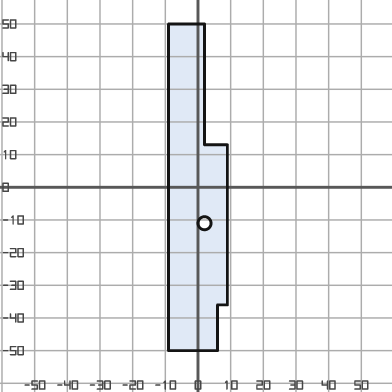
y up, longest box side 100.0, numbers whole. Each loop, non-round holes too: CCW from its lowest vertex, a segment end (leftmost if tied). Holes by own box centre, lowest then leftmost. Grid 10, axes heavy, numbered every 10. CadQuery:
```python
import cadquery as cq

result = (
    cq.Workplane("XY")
    .moveTo(-9.0, -50.0)
    .lineTo(6.0, -50.0)
    .lineTo(6.0, -36.0)
    .lineTo(9.0, -36.0)
    .lineTo(9.0, 13.0)
    .lineTo(2.0, 13.0)
    .lineTo(2.0, 50.0)
    .lineTo(-9.0, 50.0)
    .close()
    .moveTo(2.0, -11.0)
    .circle(2.0)
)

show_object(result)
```